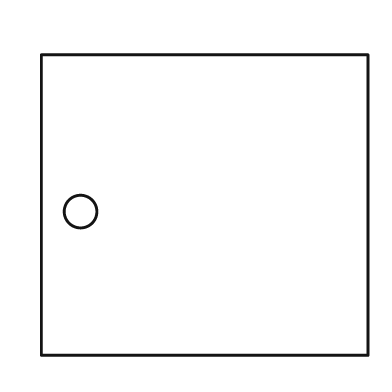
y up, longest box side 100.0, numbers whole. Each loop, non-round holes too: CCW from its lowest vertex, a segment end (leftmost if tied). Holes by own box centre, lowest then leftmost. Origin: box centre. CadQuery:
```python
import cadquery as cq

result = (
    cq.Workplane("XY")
    .moveTo(-50.0, -46.0)
    .lineTo(50.0, -46.0)
    .lineTo(50.0, 46.0)
    .lineTo(-50.0, 46.0)
    .close()
    .moveTo(-38.0, -2.0)
    .circle(5.0)
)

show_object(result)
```